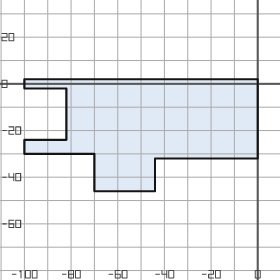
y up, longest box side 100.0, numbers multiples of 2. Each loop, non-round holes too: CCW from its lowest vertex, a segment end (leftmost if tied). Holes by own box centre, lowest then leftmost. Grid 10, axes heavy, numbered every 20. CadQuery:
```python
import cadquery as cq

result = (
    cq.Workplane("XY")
    .moveTo(-70.0, -46.0)
    .lineTo(-44.0, -46.0)
    .lineTo(-44.0, -32.0)
    .lineTo(0.0, -32.0)
    .lineTo(0.0, 2.0)
    .lineTo(-100.0, 2.0)
    .lineTo(-100.0, -2.0)
    .lineTo(-82.0, -2.0)
    .lineTo(-82.0, -24.0)
    .lineTo(-100.0, -24.0)
    .lineTo(-100.0, -30.0)
    .lineTo(-70.0, -30.0)
    .close()
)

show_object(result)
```